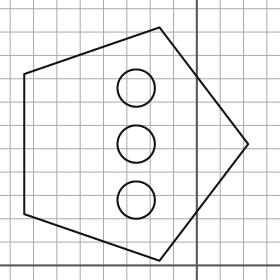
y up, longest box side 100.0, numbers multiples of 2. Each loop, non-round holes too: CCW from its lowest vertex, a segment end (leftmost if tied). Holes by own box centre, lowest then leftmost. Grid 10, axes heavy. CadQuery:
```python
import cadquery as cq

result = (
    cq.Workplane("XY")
    .moveTo(-16.0, 2.0)
    .lineTo(22.0, 52.0)
    .lineTo(-16.0, 102.0)
    .lineTo(-74.0, 82.0)
    .lineTo(-74.0, 22.0)
    .close()
    .moveTo(-26.0, 28.0)
    .circle(8.0)
    .moveTo(-26.0, 52.0)
    .circle(8.0)
    .moveTo(-26.0, 76.0)
    .circle(8.0)
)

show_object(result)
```